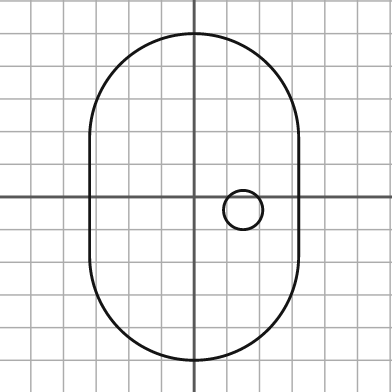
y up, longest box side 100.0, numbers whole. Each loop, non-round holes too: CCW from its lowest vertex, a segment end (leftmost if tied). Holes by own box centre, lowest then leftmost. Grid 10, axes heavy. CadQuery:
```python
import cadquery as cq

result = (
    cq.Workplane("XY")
    .moveTo(-32.0, -18.0)
    .threePointArc((0.0, -50.0), (32.0, -18.0))
    .lineTo(32.0, 18.0)
    .threePointArc((0.0, 50.0), (-32.0, 18.0))
    .close()
    .moveTo(15.0, -4.0)
    .circle(6.0)
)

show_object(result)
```